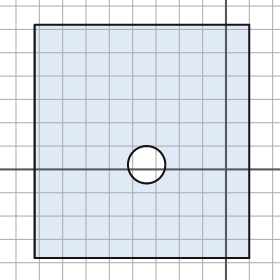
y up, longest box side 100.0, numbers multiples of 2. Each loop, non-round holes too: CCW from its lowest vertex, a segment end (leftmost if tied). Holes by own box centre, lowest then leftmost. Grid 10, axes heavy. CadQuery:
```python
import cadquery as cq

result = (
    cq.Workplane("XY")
    .moveTo(-82.0, -38.0)
    .lineTo(10.0, -38.0)
    .lineTo(10.0, 62.0)
    .lineTo(-82.0, 62.0)
    .close()
    .moveTo(-34.0, 2.0)
    .circle(8.0)
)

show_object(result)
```